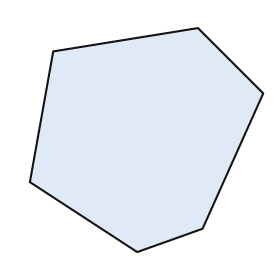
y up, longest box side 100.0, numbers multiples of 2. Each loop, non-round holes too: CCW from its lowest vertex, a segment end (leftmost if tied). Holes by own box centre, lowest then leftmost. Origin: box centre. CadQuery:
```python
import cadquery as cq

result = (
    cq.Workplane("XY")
    .moveTo(-4.0, -48.0)
    .lineTo(24.0, -38.0)
    .lineTo(50.0, 20.0)
    .lineTo(22.0, 48.0)
    .lineTo(-40.0, 38.0)
    .lineTo(-50.0, -18.0)
    .close()
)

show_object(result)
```